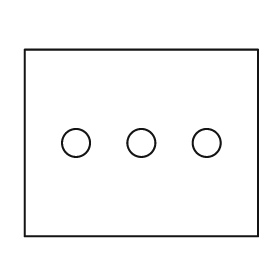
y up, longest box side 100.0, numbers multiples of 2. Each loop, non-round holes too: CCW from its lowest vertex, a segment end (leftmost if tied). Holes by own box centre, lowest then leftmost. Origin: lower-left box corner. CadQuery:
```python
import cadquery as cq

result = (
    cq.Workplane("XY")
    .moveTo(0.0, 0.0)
    .lineTo(100.0, 0.0)
    .lineTo(100.0, 80.0)
    .lineTo(0.0, 80.0)
    .close()
    .moveTo(22.0, 40.0)
    .circle(6.0)
    .moveTo(50.0, 40.0)
    .circle(6.0)
    .moveTo(78.0, 40.0)
    .circle(6.0)
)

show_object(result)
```